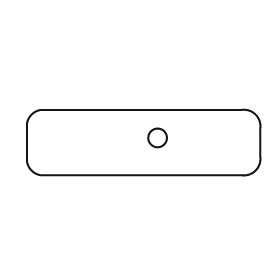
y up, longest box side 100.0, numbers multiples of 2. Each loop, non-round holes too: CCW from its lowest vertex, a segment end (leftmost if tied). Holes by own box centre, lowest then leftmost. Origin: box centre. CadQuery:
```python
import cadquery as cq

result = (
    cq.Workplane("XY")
    .moveTo(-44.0, -14.0)
    .lineTo(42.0, -14.0)
    .threePointArc((48.0, -12.0), (50.0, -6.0))
    .lineTo(50.0, 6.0)
    .threePointArc((48.0, 12.0), (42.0, 14.0))
    .lineTo(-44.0, 14.0)
    .threePointArc((-48.0, 12.0), (-50.0, 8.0))
    .lineTo(-50.0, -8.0)
    .threePointArc((-48.0, -12.0), (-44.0, -14.0))
    .close()
    .moveTo(6.0, 2.0)
    .circle(4.0)
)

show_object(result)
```